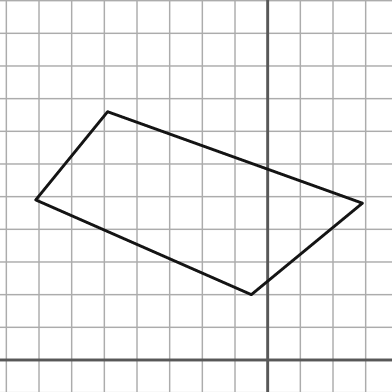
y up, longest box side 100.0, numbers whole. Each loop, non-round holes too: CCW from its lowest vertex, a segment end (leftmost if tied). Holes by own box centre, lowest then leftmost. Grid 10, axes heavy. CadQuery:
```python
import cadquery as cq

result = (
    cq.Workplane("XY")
    .moveTo(-5.0, 20.0)
    .lineTo(29.0, 48.0)
    .lineTo(-49.0, 76.0)
    .lineTo(-71.0, 49.0)
    .close()
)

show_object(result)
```